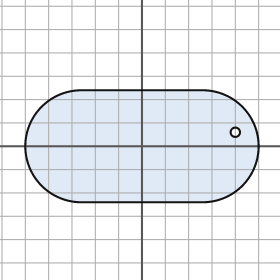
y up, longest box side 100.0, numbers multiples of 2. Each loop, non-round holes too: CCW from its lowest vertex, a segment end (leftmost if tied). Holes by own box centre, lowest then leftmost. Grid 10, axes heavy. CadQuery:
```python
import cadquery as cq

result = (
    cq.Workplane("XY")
    .moveTo(-26.0, -24.0)
    .lineTo(26.0, -24.0)
    .threePointArc((50.0, 0.0), (26.0, 24.0))
    .lineTo(-26.0, 24.0)
    .threePointArc((-50.0, 0.0), (-26.0, -24.0))
    .close()
    .moveTo(40.0, 6.0)
    .circle(2.0)
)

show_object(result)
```